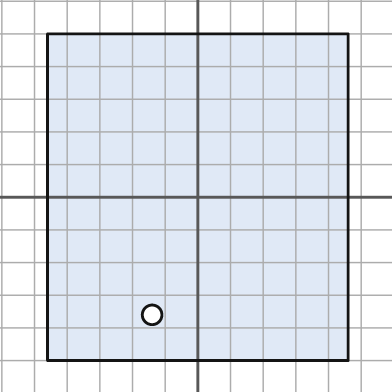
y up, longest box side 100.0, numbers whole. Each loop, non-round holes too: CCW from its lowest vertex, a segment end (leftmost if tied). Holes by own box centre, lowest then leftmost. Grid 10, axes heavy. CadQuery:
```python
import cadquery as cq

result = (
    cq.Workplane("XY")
    .moveTo(-46.0, -50.0)
    .lineTo(46.0, -50.0)
    .lineTo(46.0, 50.0)
    .lineTo(-46.0, 50.0)
    .close()
    .moveTo(-14.0, -36.0)
    .circle(3.0)
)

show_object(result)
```